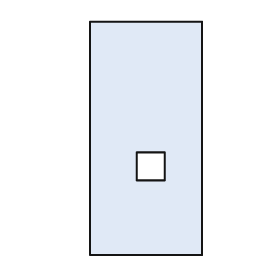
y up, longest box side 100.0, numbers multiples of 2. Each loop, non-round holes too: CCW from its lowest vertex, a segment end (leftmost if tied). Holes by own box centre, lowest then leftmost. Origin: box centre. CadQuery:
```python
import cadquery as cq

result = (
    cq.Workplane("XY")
    .moveTo(-24.0, -50.0)
    .lineTo(24.0, -50.0)
    .lineTo(24.0, 50.0)
    .lineTo(-24.0, 50.0)
    .close()
    .moveTo(-4.0, -18.0)
    .lineTo(8.0, -18.0)
    .lineTo(8.0, -6.0)
    .lineTo(-4.0, -6.0)
    .close()
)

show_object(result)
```